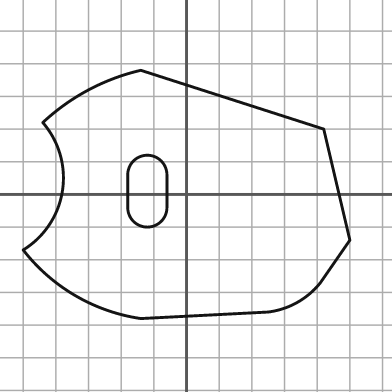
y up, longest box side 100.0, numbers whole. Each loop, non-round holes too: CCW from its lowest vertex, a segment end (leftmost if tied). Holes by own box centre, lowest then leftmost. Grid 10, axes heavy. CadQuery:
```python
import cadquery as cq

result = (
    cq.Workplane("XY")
    .moveTo(-14.0, -38.0)
    .lineTo(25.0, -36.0)
    .threePointArc((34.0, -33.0), (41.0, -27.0))
    .lineTo(50.0, -14.0)
    .lineTo(42.0, 20.0)
    .lineTo(-14.0, 38.0)
    .threePointArc((-30.0, 32.0), (-44.0, 22.0))
    .threePointArc((-38.0, 1.0), (-50.0, -17.0))
    .threePointArc((-34.0, -31.0), (-14.0, -38.0))
    .close()
    .moveTo(-18.0, -4.0)
    .threePointArc((-12.0, -10.0), (-6.0, -4.0))
    .lineTo(-6.0, 6.0)
    .threePointArc((-12.0, 12.0), (-18.0, 6.0))
    .close()
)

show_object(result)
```